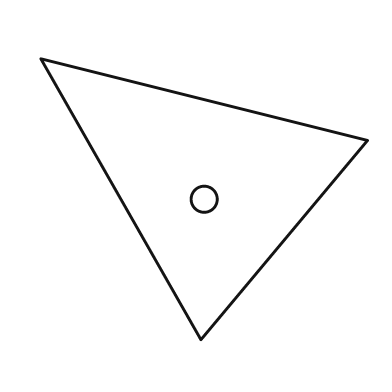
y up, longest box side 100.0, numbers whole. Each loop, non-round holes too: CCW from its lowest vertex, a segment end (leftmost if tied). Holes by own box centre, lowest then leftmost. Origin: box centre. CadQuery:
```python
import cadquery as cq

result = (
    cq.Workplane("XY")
    .moveTo(-1.0, -43.0)
    .lineTo(50.0, 18.0)
    .lineTo(-50.0, 43.0)
    .close()
    .moveTo(0.0, 0.0)
    .circle(4.0)
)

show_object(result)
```